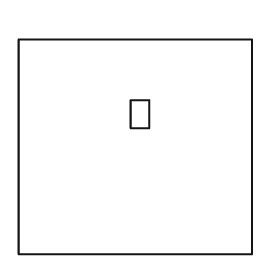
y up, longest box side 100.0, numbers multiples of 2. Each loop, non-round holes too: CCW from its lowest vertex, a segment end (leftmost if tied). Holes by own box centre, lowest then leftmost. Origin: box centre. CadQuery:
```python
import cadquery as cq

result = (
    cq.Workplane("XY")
    .moveTo(-50.0, -46.0)
    .lineTo(50.0, -46.0)
    .lineTo(50.0, 46.0)
    .lineTo(-50.0, 46.0)
    .close()
    .moveTo(-2.0, 8.0)
    .lineTo(6.0, 8.0)
    .lineTo(6.0, 20.0)
    .lineTo(-2.0, 20.0)
    .close()
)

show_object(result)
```